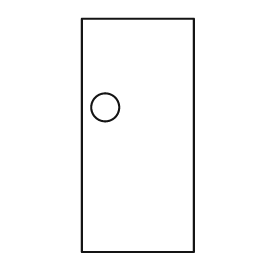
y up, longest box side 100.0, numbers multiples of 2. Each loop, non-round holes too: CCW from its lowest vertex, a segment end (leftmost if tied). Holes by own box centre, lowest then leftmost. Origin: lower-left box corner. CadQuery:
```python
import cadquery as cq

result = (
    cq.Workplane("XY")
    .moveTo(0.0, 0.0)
    .lineTo(48.0, 0.0)
    .lineTo(48.0, 100.0)
    .lineTo(0.0, 100.0)
    .close()
    .moveTo(10.0, 62.0)
    .circle(6.0)
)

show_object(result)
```